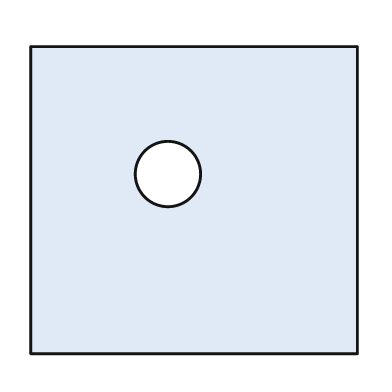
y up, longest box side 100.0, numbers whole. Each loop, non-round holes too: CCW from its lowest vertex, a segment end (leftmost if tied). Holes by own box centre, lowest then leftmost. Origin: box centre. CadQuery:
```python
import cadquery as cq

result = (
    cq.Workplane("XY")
    .moveTo(-50.0, -47.0)
    .lineTo(50.0, -47.0)
    .lineTo(50.0, 47.0)
    .lineTo(-50.0, 47.0)
    .close()
    .moveTo(-8.0, 8.0)
    .circle(10.0)
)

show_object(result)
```